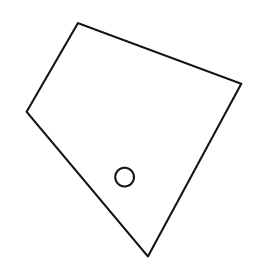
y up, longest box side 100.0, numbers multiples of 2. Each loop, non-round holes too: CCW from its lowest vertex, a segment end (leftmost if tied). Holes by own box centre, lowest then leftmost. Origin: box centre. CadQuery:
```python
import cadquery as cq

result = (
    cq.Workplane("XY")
    .moveTo(6.0, -50.0)
    .lineTo(46.0, 24.0)
    .lineTo(-24.0, 50.0)
    .lineTo(-46.0, 12.0)
    .close()
    .moveTo(-4.0, -16.0)
    .circle(4.0)
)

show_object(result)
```